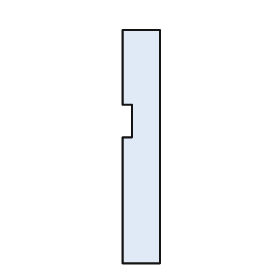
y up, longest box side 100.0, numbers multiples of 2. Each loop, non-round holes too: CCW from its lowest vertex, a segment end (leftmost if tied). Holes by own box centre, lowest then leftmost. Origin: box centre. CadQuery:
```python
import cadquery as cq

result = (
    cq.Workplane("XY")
    .moveTo(-8.0, -50.0)
    .lineTo(8.0, -50.0)
    .lineTo(8.0, 50.0)
    .lineTo(-8.0, 50.0)
    .lineTo(-8.0, 18.0)
    .lineTo(-4.0, 18.0)
    .lineTo(-4.0, 4.0)
    .lineTo(-8.0, 4.0)
    .close()
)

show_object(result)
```